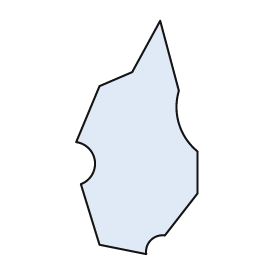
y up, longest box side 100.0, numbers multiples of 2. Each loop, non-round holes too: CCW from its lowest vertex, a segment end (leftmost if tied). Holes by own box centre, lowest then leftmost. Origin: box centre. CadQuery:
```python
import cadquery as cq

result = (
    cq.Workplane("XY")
    .moveTo(4.0, -50.0)
    .threePointArc((6.0, -44.0), (12.0, -42.0))
    .lineTo(26.0, -24.0)
    .lineTo(26.0, -6.0)
    .threePointArc((18.0, 6.0), (18.0, 20.0))
    .lineTo(10.0, 50.0)
    .lineTo(-2.0, 28.0)
    .lineTo(-16.0, 22.0)
    .lineTo(-26.0, -2.0)
    .threePointArc((-18.0, -10.0), (-24.0, -20.0))
    .lineTo(-16.0, -46.0)
    .close()
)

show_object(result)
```